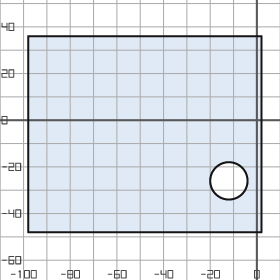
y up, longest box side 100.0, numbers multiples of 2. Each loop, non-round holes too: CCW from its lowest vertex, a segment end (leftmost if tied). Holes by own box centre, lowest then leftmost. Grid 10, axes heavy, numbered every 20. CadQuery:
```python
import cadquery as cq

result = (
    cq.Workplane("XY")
    .moveTo(-98.0, -48.0)
    .lineTo(2.0, -48.0)
    .lineTo(2.0, 36.0)
    .lineTo(-98.0, 36.0)
    .close()
    .moveTo(-12.0, -26.0)
    .circle(8.0)
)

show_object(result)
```